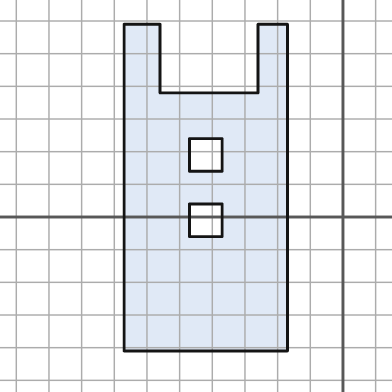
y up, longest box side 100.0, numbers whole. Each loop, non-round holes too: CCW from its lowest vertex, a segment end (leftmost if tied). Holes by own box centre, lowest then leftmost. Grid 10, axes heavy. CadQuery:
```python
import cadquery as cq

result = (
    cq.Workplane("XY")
    .moveTo(-67.0, -41.0)
    .lineTo(-17.0, -41.0)
    .lineTo(-17.0, 59.0)
    .lineTo(-26.0, 59.0)
    .lineTo(-26.0, 38.0)
    .lineTo(-56.0, 38.0)
    .lineTo(-56.0, 59.0)
    .lineTo(-67.0, 59.0)
    .close()
    .moveTo(-47.0, -6.0)
    .lineTo(-37.0, -6.0)
    .lineTo(-37.0, 4.0)
    .lineTo(-47.0, 4.0)
    .close()
    .moveTo(-47.0, 14.0)
    .lineTo(-37.0, 14.0)
    .lineTo(-37.0, 24.0)
    .lineTo(-47.0, 24.0)
    .close()
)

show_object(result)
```